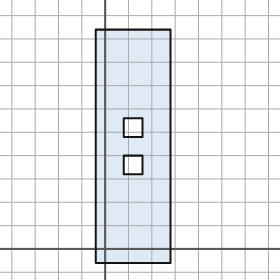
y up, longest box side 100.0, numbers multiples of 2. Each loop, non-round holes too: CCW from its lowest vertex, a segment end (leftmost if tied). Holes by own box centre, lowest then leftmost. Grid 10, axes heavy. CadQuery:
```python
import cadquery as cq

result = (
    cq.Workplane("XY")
    .moveTo(-4.0, -6.0)
    .lineTo(28.0, -6.0)
    .lineTo(28.0, 94.0)
    .lineTo(-4.0, 94.0)
    .close()
    .moveTo(8.0, 32.0)
    .lineTo(16.0, 32.0)
    .lineTo(16.0, 40.0)
    .lineTo(8.0, 40.0)
    .close()
    .moveTo(8.0, 48.0)
    .lineTo(16.0, 48.0)
    .lineTo(16.0, 56.0)
    .lineTo(8.0, 56.0)
    .close()
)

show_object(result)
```